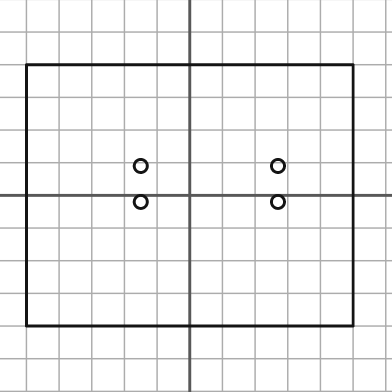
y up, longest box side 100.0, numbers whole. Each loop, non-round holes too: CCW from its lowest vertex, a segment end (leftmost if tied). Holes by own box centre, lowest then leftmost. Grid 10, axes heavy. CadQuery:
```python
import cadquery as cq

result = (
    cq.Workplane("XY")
    .moveTo(-50.0, -40.0)
    .lineTo(50.0, -40.0)
    .lineTo(50.0, 40.0)
    .lineTo(-50.0, 40.0)
    .close()
    .moveTo(-15.0, -2.0)
    .circle(2.0)
    .moveTo(27.0, -2.0)
    .circle(2.0)
    .moveTo(-15.0, 9.0)
    .circle(2.0)
    .moveTo(27.0, 9.0)
    .circle(2.0)
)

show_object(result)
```